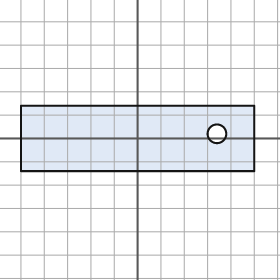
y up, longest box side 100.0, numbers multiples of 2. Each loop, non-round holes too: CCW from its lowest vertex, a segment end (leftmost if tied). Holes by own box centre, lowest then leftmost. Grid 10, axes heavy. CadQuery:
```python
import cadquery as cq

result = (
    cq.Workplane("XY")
    .moveTo(-50.0, -14.0)
    .lineTo(50.0, -14.0)
    .lineTo(50.0, 14.0)
    .lineTo(-50.0, 14.0)
    .close()
    .moveTo(34.0, 2.0)
    .circle(4.0)
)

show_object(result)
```